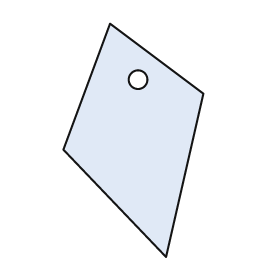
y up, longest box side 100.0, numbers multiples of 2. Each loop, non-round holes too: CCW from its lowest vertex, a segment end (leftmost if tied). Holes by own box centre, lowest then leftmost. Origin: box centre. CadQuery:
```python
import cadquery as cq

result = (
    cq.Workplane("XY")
    .moveTo(14.0, -50.0)
    .lineTo(30.0, 20.0)
    .lineTo(-10.0, 50.0)
    .lineTo(-30.0, -4.0)
    .close()
    .moveTo(2.0, 26.0)
    .circle(4.0)
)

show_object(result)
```